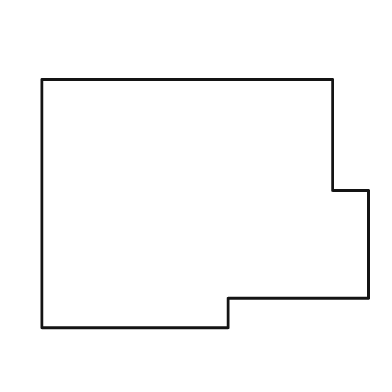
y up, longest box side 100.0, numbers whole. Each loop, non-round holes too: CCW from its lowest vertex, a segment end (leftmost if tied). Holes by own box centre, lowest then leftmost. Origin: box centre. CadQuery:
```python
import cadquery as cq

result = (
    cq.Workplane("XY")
    .moveTo(-50.0, -38.0)
    .lineTo(7.0, -38.0)
    .lineTo(7.0, -29.0)
    .lineTo(50.0, -29.0)
    .lineTo(50.0, 4.0)
    .lineTo(39.0, 4.0)
    .lineTo(39.0, 38.0)
    .lineTo(-50.0, 38.0)
    .close()
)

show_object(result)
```